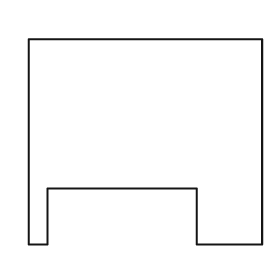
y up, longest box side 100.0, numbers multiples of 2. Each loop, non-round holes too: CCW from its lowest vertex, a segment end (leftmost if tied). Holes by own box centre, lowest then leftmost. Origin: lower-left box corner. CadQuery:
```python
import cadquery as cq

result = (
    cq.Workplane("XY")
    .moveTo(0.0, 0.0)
    .lineTo(8.0, 0.0)
    .lineTo(8.0, 24.0)
    .lineTo(72.0, 24.0)
    .lineTo(72.0, 0.0)
    .lineTo(100.0, 0.0)
    .lineTo(100.0, 88.0)
    .lineTo(0.0, 88.0)
    .close()
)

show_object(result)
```